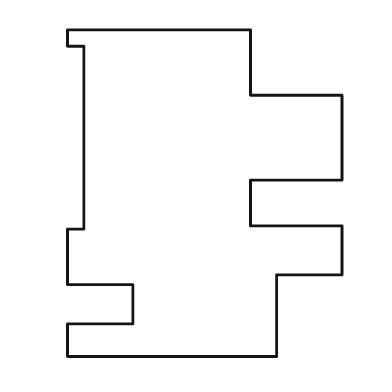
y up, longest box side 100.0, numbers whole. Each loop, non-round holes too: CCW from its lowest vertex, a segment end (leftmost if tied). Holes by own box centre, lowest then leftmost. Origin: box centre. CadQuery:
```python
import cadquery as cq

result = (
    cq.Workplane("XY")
    .moveTo(-42.0, -50.0)
    .lineTo(22.0, -50.0)
    .lineTo(22.0, -25.0)
    .lineTo(42.0, -25.0)
    .lineTo(42.0, -10.0)
    .lineTo(14.0, -10.0)
    .lineTo(14.0, 4.0)
    .lineTo(42.0, 4.0)
    .lineTo(42.0, 30.0)
    .lineTo(14.0, 30.0)
    .lineTo(14.0, 50.0)
    .lineTo(-42.0, 50.0)
    .lineTo(-42.0, 45.0)
    .lineTo(-37.0, 45.0)
    .lineTo(-37.0, -11.0)
    .lineTo(-42.0, -11.0)
    .lineTo(-42.0, -28.0)
    .lineTo(-22.0, -28.0)
    .lineTo(-22.0, -40.0)
    .lineTo(-42.0, -40.0)
    .close()
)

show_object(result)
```